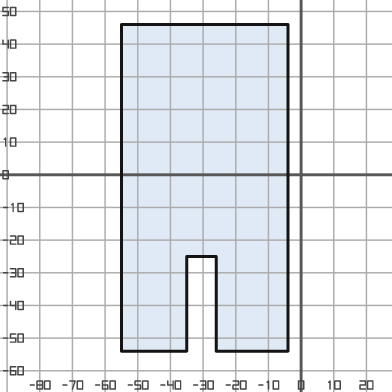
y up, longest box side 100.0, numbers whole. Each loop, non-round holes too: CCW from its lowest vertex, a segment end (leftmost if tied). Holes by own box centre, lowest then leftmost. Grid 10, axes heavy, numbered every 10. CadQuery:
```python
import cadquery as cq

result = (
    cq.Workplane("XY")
    .moveTo(-55.0, -54.0)
    .lineTo(-35.0, -54.0)
    .lineTo(-35.0, -25.0)
    .lineTo(-26.0, -25.0)
    .lineTo(-26.0, -54.0)
    .lineTo(-4.0, -54.0)
    .lineTo(-4.0, 46.0)
    .lineTo(-55.0, 46.0)
    .close()
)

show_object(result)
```